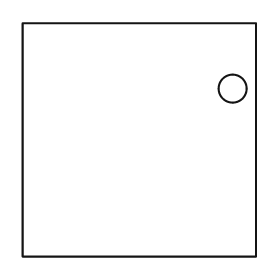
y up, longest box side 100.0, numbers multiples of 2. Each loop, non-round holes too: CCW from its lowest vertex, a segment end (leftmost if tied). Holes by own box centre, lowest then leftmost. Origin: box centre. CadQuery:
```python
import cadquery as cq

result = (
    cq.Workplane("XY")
    .moveTo(-50.0, -50.0)
    .lineTo(50.0, -50.0)
    .lineTo(50.0, 50.0)
    .lineTo(-50.0, 50.0)
    .close()
    .moveTo(40.0, 22.0)
    .circle(6.0)
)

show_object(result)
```